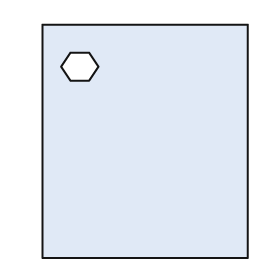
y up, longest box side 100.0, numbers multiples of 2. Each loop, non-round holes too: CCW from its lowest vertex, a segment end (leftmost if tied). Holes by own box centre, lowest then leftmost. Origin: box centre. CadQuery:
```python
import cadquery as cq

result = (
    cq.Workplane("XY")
    .moveTo(-44.0, -50.0)
    .lineTo(44.0, -50.0)
    .lineTo(44.0, 50.0)
    .lineTo(-44.0, 50.0)
    .close()
    .moveTo(-32.0, 26.0)
    .lineTo(-24.0, 26.0)
    .lineTo(-20.0, 32.0)
    .lineTo(-24.0, 38.0)
    .lineTo(-32.0, 38.0)
    .lineTo(-36.0, 32.0)
    .close()
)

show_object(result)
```